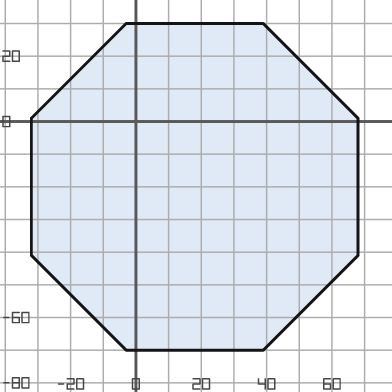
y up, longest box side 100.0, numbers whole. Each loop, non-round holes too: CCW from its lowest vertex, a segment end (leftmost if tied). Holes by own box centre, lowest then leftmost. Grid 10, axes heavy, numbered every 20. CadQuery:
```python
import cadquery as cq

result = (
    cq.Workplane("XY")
    .moveTo(-3.0, -70.0)
    .lineTo(39.0, -70.0)
    .lineTo(68.0, -41.0)
    .lineTo(68.0, 1.0)
    .lineTo(39.0, 30.0)
    .lineTo(-3.0, 30.0)
    .lineTo(-32.0, 1.0)
    .lineTo(-32.0, -41.0)
    .close()
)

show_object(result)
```